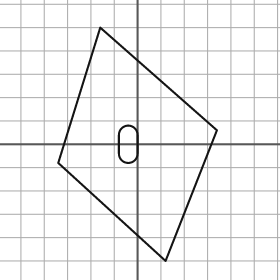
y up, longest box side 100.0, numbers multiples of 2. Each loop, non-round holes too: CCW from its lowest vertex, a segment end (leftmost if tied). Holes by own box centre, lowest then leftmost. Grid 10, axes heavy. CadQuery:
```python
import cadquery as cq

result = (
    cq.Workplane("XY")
    .moveTo(12.0, -50.0)
    .lineTo(34.0, 6.0)
    .lineTo(-16.0, 50.0)
    .lineTo(-34.0, -8.0)
    .close()
    .moveTo(-8.0, -4.0)
    .threePointArc((-4.0, -8.0), (0.0, -4.0))
    .lineTo(0.0, 4.0)
    .threePointArc((-4.0, 8.0), (-8.0, 4.0))
    .close()
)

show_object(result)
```